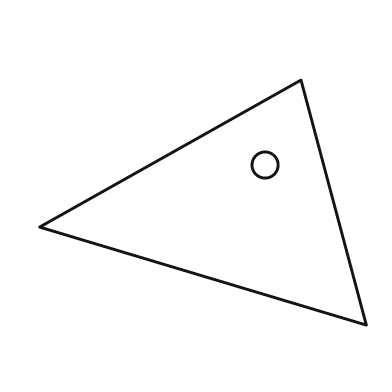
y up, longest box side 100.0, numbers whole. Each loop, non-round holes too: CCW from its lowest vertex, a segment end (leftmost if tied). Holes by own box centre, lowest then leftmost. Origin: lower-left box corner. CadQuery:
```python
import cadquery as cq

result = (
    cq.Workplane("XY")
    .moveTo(100.0, 0.0)
    .lineTo(80.0, 75.0)
    .lineTo(0.0, 30.0)
    .close()
    .moveTo(69.0, 49.0)
    .circle(4.0)
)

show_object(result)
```